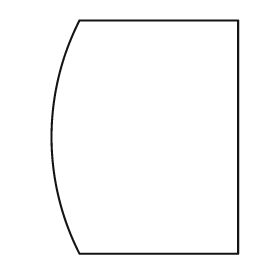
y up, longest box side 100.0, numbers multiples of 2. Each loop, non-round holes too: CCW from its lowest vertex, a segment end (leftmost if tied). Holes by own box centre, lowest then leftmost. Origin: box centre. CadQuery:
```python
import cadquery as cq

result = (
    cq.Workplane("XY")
    .moveTo(-28.0, -50.0)
    .lineTo(40.0, -50.0)
    .lineTo(40.0, 50.0)
    .lineTo(-28.0, 50.0)
    .threePointArc((-40.0, 0.0), (-28.0, -50.0))
    .close()
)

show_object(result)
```